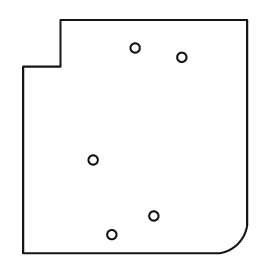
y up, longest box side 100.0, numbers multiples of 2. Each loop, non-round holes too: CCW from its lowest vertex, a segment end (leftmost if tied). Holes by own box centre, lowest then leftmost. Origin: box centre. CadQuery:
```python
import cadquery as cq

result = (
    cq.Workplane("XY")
    .moveTo(-48.0, -50.0)
    .lineTo(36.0, -50.0)
    .threePointArc((44.0, -46.0), (48.0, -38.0))
    .lineTo(48.0, 50.0)
    .lineTo(-32.0, 50.0)
    .lineTo(-32.0, 30.0)
    .lineTo(-48.0, 30.0)
    .close()
    .moveTo(-10.0, -42.0)
    .circle(2.0)
    .moveTo(8.0, -34.0)
    .circle(2.0)
    .moveTo(-18.0, -10.0)
    .circle(2.0)
    .moveTo(20.0, 34.0)
    .circle(2.0)
    .moveTo(0.0, 38.0)
    .circle(2.0)
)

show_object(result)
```